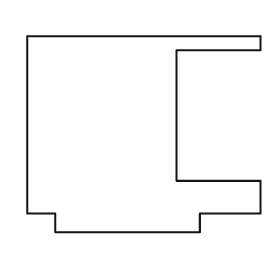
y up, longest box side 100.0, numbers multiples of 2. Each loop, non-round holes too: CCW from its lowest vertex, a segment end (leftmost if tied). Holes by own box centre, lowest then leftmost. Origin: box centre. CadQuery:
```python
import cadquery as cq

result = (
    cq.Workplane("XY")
    .moveTo(-38.0, -42.0)
    .lineTo(24.0, -42.0)
    .lineTo(24.0, -34.0)
    .lineTo(50.0, -34.0)
    .lineTo(50.0, -20.0)
    .lineTo(14.0, -20.0)
    .lineTo(14.0, 36.0)
    .lineTo(50.0, 36.0)
    .lineTo(50.0, 42.0)
    .lineTo(-50.0, 42.0)
    .lineTo(-50.0, -34.0)
    .lineTo(-38.0, -34.0)
    .close()
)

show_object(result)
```